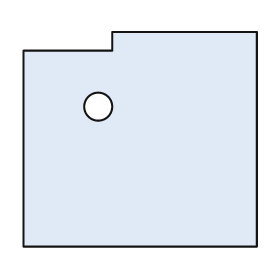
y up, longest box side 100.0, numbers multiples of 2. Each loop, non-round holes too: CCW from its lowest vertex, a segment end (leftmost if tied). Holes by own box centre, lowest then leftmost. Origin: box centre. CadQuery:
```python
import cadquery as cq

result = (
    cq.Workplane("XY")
    .moveTo(-50.0, -46.0)
    .lineTo(50.0, -46.0)
    .lineTo(50.0, 46.0)
    .lineTo(-12.0, 46.0)
    .lineTo(-12.0, 38.0)
    .lineTo(-50.0, 38.0)
    .close()
    .moveTo(-18.0, 14.0)
    .circle(6.0)
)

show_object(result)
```